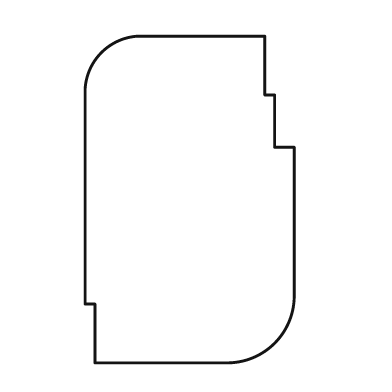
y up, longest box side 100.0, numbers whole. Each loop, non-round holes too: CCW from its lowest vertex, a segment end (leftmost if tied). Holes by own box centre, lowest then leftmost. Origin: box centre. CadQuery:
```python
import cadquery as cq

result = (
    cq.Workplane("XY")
    .moveTo(-29.0, -50.0)
    .lineTo(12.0, -50.0)
    .threePointArc((26.0, -44.0), (32.0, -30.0))
    .lineTo(32.0, 16.0)
    .lineTo(26.0, 16.0)
    .lineTo(26.0, 32.0)
    .lineTo(23.0, 32.0)
    .lineTo(23.0, 50.0)
    .lineTo(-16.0, 50.0)
    .threePointArc((-27.0, 45.0), (-32.0, 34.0))
    .lineTo(-32.0, -32.0)
    .lineTo(-29.0, -32.0)
    .close()
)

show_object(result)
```